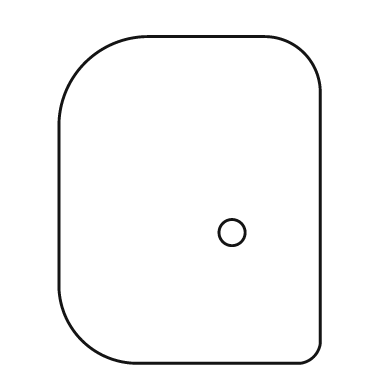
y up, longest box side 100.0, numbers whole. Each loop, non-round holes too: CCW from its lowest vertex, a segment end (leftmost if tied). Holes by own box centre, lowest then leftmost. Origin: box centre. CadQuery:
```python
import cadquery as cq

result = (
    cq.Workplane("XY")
    .moveTo(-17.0, -50.0)
    .lineTo(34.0, -50.0)
    .threePointArc((38.0, -48.0), (40.0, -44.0))
    .lineTo(40.0, 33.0)
    .threePointArc((35.0, 45.0), (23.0, 50.0))
    .lineTo(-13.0, 50.0)
    .threePointArc((-32.0, 42.0), (-40.0, 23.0))
    .lineTo(-40.0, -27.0)
    .threePointArc((-33.0, -43.0), (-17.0, -50.0))
    .close()
    .moveTo(13.0, -10.0)
    .circle(4.0)
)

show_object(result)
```